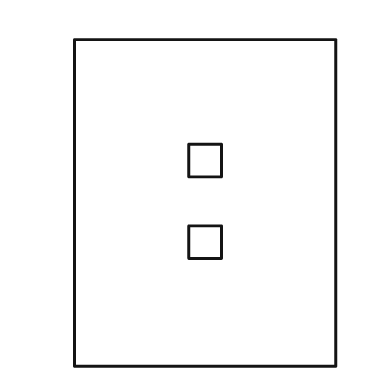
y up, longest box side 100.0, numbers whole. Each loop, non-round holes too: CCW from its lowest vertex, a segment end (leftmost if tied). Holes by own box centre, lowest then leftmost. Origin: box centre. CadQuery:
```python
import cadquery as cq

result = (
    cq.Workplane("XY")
    .moveTo(-40.0, -50.0)
    .lineTo(40.0, -50.0)
    .lineTo(40.0, 50.0)
    .lineTo(-40.0, 50.0)
    .close()
    .moveTo(-5.0, -17.0)
    .lineTo(5.0, -17.0)
    .lineTo(5.0, -7.0)
    .lineTo(-5.0, -7.0)
    .close()
    .moveTo(-5.0, 8.0)
    .lineTo(5.0, 8.0)
    .lineTo(5.0, 18.0)
    .lineTo(-5.0, 18.0)
    .close()
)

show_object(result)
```